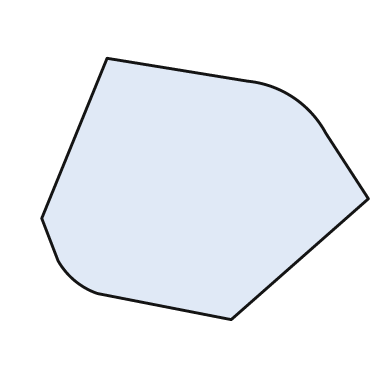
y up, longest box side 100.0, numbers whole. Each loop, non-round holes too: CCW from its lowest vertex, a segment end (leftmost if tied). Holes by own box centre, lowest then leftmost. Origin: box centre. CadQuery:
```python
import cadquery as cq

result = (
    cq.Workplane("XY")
    .moveTo(8.0, -40.0)
    .lineTo(50.0, -3.0)
    .lineTo(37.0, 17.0)
    .threePointArc((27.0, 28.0), (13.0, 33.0))
    .lineTo(-30.0, 40.0)
    .lineTo(-50.0, -9.0)
    .lineTo(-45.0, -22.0)
    .threePointArc((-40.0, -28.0), (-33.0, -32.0))
    .close()
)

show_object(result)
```